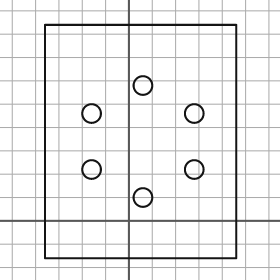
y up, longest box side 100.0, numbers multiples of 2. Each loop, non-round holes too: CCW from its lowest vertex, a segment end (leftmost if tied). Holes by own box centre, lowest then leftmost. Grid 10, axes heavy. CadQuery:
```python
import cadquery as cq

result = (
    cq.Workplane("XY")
    .moveTo(-36.0, -16.0)
    .lineTo(46.0, -16.0)
    .lineTo(46.0, 84.0)
    .lineTo(-36.0, 84.0)
    .close()
    .moveTo(6.0, 10.0)
    .circle(4.0)
    .moveTo(-16.0, 22.0)
    .circle(4.0)
    .moveTo(28.0, 22.0)
    .circle(4.0)
    .moveTo(-16.0, 46.0)
    .circle(4.0)
    .moveTo(28.0, 46.0)
    .circle(4.0)
    .moveTo(6.0, 58.0)
    .circle(4.0)
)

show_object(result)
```